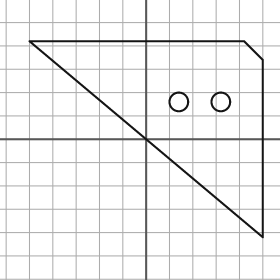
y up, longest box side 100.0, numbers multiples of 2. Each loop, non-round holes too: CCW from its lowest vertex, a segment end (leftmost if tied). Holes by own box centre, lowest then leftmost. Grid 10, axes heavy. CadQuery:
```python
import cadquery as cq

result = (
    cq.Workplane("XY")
    .moveTo(50.0, -42.0)
    .lineTo(50.0, 34.0)
    .lineTo(42.0, 42.0)
    .lineTo(-50.0, 42.0)
    .close()
    .moveTo(14.0, 16.0)
    .circle(4.0)
    .moveTo(32.0, 16.0)
    .circle(4.0)
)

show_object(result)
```